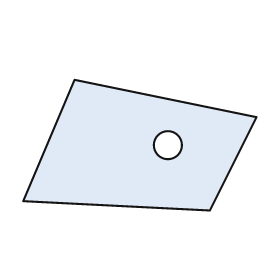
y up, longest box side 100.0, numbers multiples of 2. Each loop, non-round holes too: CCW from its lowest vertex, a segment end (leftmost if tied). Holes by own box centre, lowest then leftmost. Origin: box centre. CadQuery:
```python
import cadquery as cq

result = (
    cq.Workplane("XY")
    .moveTo(30.0, -28.0)
    .lineTo(50.0, 12.0)
    .lineTo(-28.0, 28.0)
    .lineTo(-50.0, -24.0)
    .close()
    .moveTo(12.0, 0.0)
    .circle(6.0)
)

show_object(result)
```